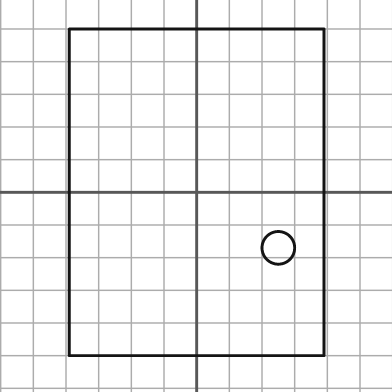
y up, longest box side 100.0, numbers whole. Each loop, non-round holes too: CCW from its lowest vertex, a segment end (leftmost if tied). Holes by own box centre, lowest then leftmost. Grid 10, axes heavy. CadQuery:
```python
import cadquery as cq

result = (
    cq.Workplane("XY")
    .moveTo(-39.0, -50.0)
    .lineTo(39.0, -50.0)
    .lineTo(39.0, 50.0)
    .lineTo(-39.0, 50.0)
    .close()
    .moveTo(25.0, -17.0)
    .circle(5.0)
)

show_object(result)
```